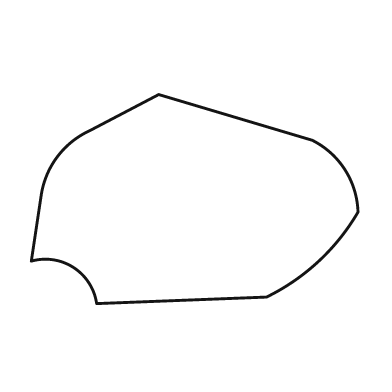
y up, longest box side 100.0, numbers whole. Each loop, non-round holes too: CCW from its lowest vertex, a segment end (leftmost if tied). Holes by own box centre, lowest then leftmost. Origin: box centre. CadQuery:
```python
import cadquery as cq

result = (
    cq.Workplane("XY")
    .moveTo(-30.0, -32.0)
    .lineTo(22.0, -30.0)
    .threePointArc((38.0, -19.0), (50.0, -4.0))
    .threePointArc((46.0, 9.0), (36.0, 18.0))
    .lineTo(-11.0, 32.0)
    .lineTo(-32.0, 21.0)
    .threePointArc((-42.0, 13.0), (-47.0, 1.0))
    .lineTo(-50.0, -19.0)
    .threePointArc((-37.0, -21.0), (-30.0, -32.0))
    .close()
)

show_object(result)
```